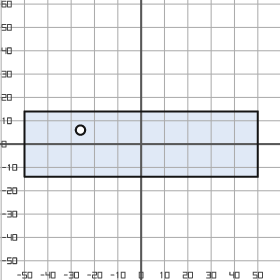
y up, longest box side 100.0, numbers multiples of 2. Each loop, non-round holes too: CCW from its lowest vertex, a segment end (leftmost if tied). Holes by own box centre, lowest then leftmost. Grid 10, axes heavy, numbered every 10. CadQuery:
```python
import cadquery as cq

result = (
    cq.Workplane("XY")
    .moveTo(-50.0, -14.0)
    .lineTo(50.0, -14.0)
    .lineTo(50.0, 14.0)
    .lineTo(-50.0, 14.0)
    .close()
    .moveTo(-26.0, 6.0)
    .circle(2.0)
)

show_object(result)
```